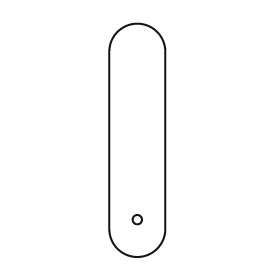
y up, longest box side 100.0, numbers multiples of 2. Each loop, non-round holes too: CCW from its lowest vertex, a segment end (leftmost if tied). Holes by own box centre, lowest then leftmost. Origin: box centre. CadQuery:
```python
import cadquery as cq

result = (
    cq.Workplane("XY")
    .moveTo(-12.0, -38.0)
    .threePointArc((0.0, -50.0), (12.0, -38.0))
    .lineTo(12.0, 38.0)
    .threePointArc((0.0, 50.0), (-12.0, 38.0))
    .close()
    .moveTo(0.0, -34.0)
    .circle(2.0)
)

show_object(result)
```